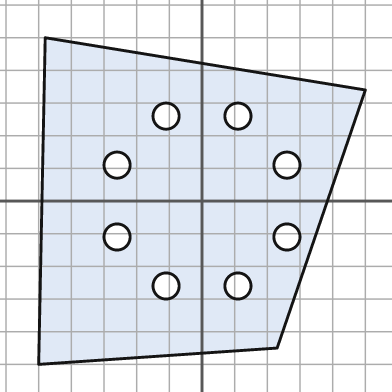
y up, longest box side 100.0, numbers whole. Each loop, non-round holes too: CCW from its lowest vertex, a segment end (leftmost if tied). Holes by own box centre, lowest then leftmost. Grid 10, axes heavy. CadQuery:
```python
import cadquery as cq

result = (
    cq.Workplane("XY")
    .moveTo(-50.0, -50.0)
    .lineTo(23.0, -45.0)
    .lineTo(50.0, 34.0)
    .lineTo(-48.0, 50.0)
    .close()
    .moveTo(-11.0, -26.0)
    .circle(4.0)
    .moveTo(11.0, -26.0)
    .circle(4.0)
    .moveTo(-26.0, -11.0)
    .circle(4.0)
    .moveTo(26.0, -11.0)
    .circle(4.0)
    .moveTo(-26.0, 11.0)
    .circle(4.0)
    .moveTo(26.0, 11.0)
    .circle(4.0)
    .moveTo(-11.0, 26.0)
    .circle(4.0)
    .moveTo(11.0, 26.0)
    .circle(4.0)
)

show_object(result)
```